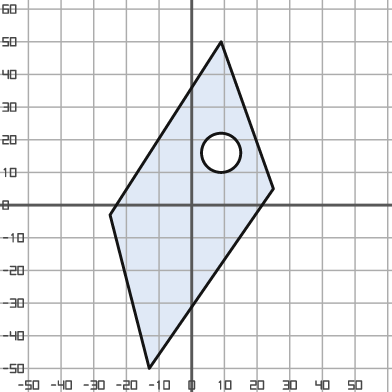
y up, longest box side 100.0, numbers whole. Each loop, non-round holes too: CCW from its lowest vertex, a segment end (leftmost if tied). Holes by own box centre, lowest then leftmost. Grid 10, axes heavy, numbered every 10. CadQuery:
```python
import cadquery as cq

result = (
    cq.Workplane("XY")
    .moveTo(-13.0, -50.0)
    .lineTo(25.0, 5.0)
    .lineTo(9.0, 50.0)
    .lineTo(-25.0, -3.0)
    .close()
    .moveTo(9.0, 16.0)
    .circle(6.0)
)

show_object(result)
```